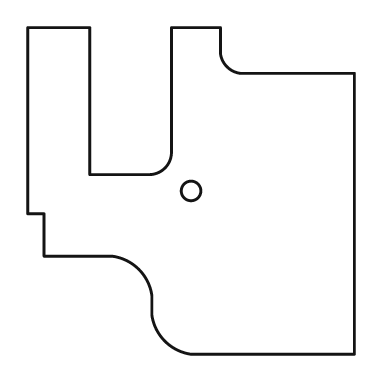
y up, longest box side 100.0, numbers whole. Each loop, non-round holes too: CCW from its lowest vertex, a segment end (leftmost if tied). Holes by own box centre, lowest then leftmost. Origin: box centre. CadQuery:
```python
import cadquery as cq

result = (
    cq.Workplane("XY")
    .moveTo(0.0, -50.0)
    .lineTo(50.0, -50.0)
    .lineTo(50.0, 36.0)
    .lineTo(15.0, 36.0)
    .threePointArc((11.0, 38.0), (9.0, 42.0))
    .lineTo(9.0, 50.0)
    .lineTo(-6.0, 50.0)
    .lineTo(-6.0, 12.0)
    .threePointArc((-8.0, 7.0), (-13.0, 5.0))
    .lineTo(-31.0, 5.0)
    .lineTo(-31.0, 50.0)
    .lineTo(-50.0, 50.0)
    .lineTo(-50.0, -7.0)
    .lineTo(-45.0, -7.0)
    .lineTo(-45.0, -20.0)
    .lineTo(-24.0, -20.0)
    .threePointArc((-16.0, -24.0), (-12.0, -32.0))
    .lineTo(-12.0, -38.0)
    .threePointArc((-8.0, -46.0), (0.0, -50.0))
    .close()
    .moveTo(0.0, 0.0)
    .circle(3.0)
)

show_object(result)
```